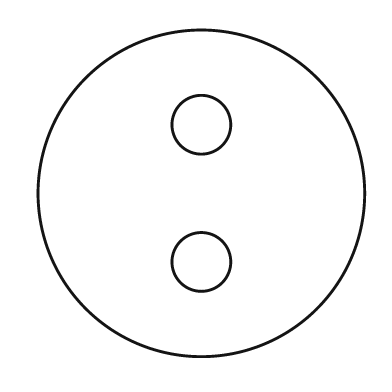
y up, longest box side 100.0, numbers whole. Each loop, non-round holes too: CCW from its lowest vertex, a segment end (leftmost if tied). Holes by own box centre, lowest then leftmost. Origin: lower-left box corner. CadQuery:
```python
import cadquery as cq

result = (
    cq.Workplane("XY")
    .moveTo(50.0, 50.0)
    .circle(50.0)
    .moveTo(50.0, 29.0)
    .circle(9.0)
    .moveTo(50.0, 71.0)
    .circle(9.0)
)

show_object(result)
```